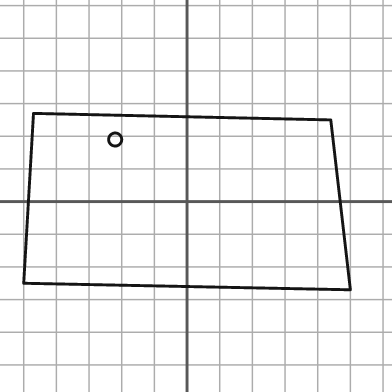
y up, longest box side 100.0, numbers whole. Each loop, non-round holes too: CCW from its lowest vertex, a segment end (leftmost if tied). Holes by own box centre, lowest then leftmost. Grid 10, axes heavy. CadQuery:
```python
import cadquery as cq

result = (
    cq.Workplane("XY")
    .moveTo(50.0, -27.0)
    .lineTo(44.0, 25.0)
    .lineTo(-47.0, 27.0)
    .lineTo(-50.0, -25.0)
    .close()
    .moveTo(-22.0, 19.0)
    .circle(2.0)
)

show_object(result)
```